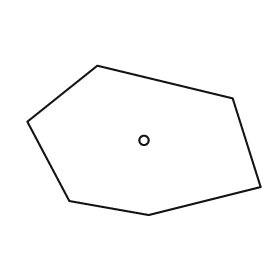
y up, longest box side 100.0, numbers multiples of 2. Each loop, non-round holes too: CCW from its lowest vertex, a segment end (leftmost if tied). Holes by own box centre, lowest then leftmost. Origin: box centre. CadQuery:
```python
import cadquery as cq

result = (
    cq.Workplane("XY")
    .moveTo(2.0, -32.0)
    .lineTo(50.0, -20.0)
    .lineTo(38.0, 18.0)
    .lineTo(-20.0, 32.0)
    .lineTo(-50.0, 8.0)
    .lineTo(-32.0, -26.0)
    .close()
    .moveTo(0.0, 0.0)
    .circle(2.0)
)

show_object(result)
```